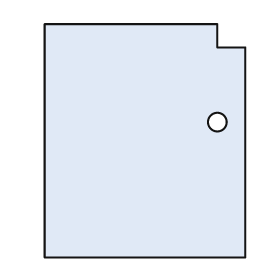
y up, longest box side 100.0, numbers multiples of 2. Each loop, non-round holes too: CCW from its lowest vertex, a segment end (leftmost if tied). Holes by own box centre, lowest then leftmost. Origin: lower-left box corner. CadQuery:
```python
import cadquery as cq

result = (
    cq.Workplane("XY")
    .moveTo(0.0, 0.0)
    .lineTo(86.0, 0.0)
    .lineTo(86.0, 90.0)
    .lineTo(74.0, 90.0)
    .lineTo(74.0, 100.0)
    .lineTo(0.0, 100.0)
    .close()
    .moveTo(74.0, 58.0)
    .circle(4.0)
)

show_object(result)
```